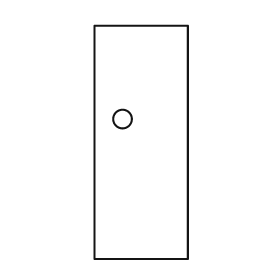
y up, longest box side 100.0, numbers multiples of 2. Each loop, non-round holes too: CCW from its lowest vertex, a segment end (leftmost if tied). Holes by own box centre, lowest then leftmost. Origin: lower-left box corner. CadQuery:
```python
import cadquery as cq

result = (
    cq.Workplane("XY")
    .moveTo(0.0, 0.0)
    .lineTo(40.0, 0.0)
    .lineTo(40.0, 100.0)
    .lineTo(0.0, 100.0)
    .close()
    .moveTo(12.0, 60.0)
    .circle(4.0)
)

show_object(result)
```